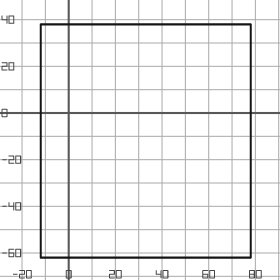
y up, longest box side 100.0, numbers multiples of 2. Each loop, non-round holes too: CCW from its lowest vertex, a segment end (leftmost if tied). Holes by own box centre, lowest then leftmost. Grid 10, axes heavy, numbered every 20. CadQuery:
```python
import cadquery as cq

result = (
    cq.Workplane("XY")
    .moveTo(-12.0, -62.0)
    .lineTo(78.0, -62.0)
    .lineTo(78.0, 38.0)
    .lineTo(-12.0, 38.0)
    .close()
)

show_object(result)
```